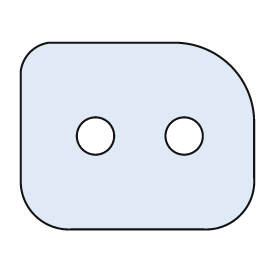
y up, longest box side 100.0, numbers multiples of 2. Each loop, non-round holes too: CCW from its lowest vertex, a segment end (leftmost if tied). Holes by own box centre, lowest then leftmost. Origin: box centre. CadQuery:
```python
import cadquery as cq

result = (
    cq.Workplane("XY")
    .moveTo(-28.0, -40.0)
    .lineTo(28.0, -40.0)
    .threePointArc((44.0, -34.0), (50.0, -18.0))
    .lineTo(50.0, 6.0)
    .threePointArc((40.0, 30.0), (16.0, 40.0))
    .lineTo(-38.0, 40.0)
    .threePointArc((-46.0, 36.0), (-50.0, 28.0))
    .lineTo(-50.0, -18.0)
    .threePointArc((-44.0, -34.0), (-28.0, -40.0))
    .close()
    .moveTo(-18.0, 0.0)
    .circle(8.0)
    .moveTo(20.0, 0.0)
    .circle(8.0)
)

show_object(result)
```